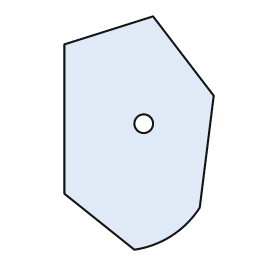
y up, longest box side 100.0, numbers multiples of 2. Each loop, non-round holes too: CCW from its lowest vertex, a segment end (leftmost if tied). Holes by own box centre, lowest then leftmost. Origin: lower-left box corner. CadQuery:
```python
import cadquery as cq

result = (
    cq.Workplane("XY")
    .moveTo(30.0, 0.0)
    .threePointArc((46.0, 6.0), (58.0, 18.0))
    .lineTo(64.0, 66.0)
    .lineTo(38.0, 100.0)
    .lineTo(0.0, 88.0)
    .lineTo(0.0, 24.0)
    .close()
    .moveTo(34.0, 54.0)
    .circle(4.0)
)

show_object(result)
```